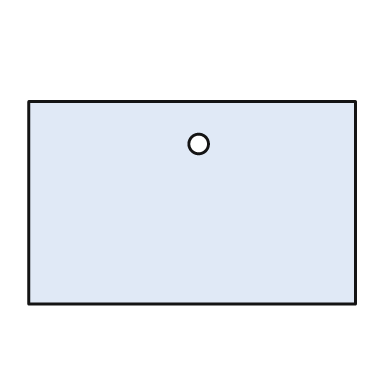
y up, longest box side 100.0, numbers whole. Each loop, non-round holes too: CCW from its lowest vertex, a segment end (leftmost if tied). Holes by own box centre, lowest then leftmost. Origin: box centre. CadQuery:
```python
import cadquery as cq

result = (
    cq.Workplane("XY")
    .moveTo(-50.0, -31.0)
    .lineTo(50.0, -31.0)
    .lineTo(50.0, 31.0)
    .lineTo(-50.0, 31.0)
    .close()
    .moveTo(2.0, 18.0)
    .circle(3.0)
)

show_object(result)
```